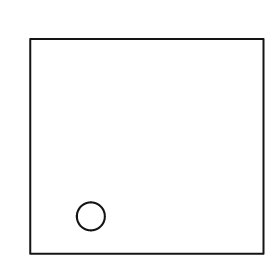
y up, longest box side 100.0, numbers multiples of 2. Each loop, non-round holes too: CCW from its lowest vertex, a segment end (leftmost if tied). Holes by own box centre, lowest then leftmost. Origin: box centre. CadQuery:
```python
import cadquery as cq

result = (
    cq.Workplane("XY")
    .moveTo(-50.0, -46.0)
    .lineTo(50.0, -46.0)
    .lineTo(50.0, 46.0)
    .lineTo(-50.0, 46.0)
    .close()
    .moveTo(-24.0, -30.0)
    .circle(6.0)
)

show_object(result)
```